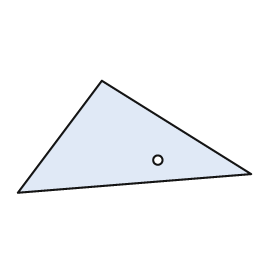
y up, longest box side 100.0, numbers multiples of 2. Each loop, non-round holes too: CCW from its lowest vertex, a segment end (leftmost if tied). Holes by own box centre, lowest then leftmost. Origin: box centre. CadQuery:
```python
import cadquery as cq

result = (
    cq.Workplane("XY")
    .moveTo(-50.0, -24.0)
    .lineTo(50.0, -16.0)
    .lineTo(-14.0, 24.0)
    .close()
    .moveTo(10.0, -10.0)
    .circle(2.0)
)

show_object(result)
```